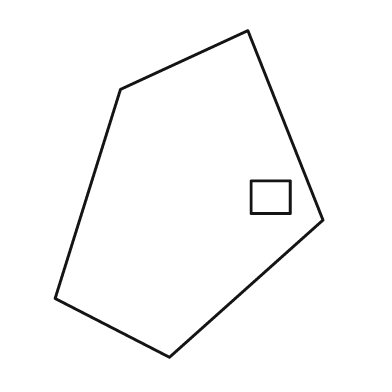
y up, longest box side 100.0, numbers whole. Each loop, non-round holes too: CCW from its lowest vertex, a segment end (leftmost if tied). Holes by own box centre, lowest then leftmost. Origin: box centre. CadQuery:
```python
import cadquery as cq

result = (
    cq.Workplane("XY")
    .moveTo(-6.0, -50.0)
    .lineTo(41.0, -8.0)
    .lineTo(18.0, 50.0)
    .lineTo(-21.0, 32.0)
    .lineTo(-41.0, -32.0)
    .close()
    .moveTo(19.0, -6.0)
    .lineTo(31.0, -6.0)
    .lineTo(31.0, 4.0)
    .lineTo(19.0, 4.0)
    .close()
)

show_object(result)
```